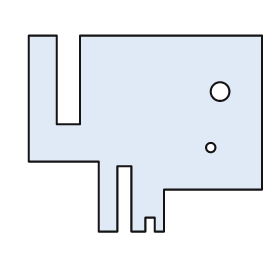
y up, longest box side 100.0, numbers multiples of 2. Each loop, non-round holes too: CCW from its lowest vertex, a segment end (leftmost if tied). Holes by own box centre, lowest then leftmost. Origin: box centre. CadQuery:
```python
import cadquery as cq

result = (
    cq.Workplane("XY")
    .moveTo(-20.0, -42.0)
    .lineTo(-12.0, -42.0)
    .lineTo(-12.0, -14.0)
    .lineTo(-6.0, -14.0)
    .lineTo(-6.0, -42.0)
    .lineTo(0.0, -42.0)
    .lineTo(0.0, -36.0)
    .lineTo(4.0, -36.0)
    .lineTo(4.0, -42.0)
    .lineTo(8.0, -42.0)
    .lineTo(8.0, -24.0)
    .lineTo(50.0, -24.0)
    .lineTo(50.0, 42.0)
    .lineTo(-28.0, 42.0)
    .lineTo(-28.0, 4.0)
    .lineTo(-38.0, 4.0)
    .lineTo(-38.0, 42.0)
    .lineTo(-50.0, 42.0)
    .lineTo(-50.0, -12.0)
    .lineTo(-20.0, -12.0)
    .close()
    .moveTo(28.0, -6.0)
    .circle(2.0)
    .moveTo(32.0, 18.0)
    .circle(4.0)
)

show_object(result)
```